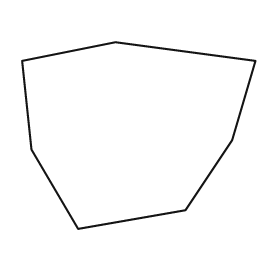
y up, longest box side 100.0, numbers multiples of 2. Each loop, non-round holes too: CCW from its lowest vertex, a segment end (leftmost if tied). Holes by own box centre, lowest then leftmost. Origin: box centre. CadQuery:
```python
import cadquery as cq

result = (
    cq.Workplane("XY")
    .moveTo(-26.0, -40.0)
    .lineTo(20.0, -32.0)
    .lineTo(40.0, -2.0)
    .lineTo(50.0, 32.0)
    .lineTo(-10.0, 40.0)
    .lineTo(-50.0, 32.0)
    .lineTo(-46.0, -6.0)
    .close()
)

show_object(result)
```